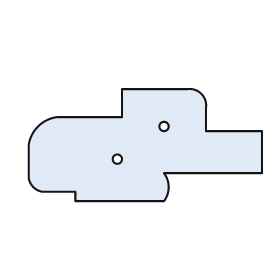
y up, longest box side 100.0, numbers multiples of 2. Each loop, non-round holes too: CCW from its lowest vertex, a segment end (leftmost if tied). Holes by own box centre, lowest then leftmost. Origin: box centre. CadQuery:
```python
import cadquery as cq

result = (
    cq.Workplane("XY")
    .moveTo(-30.0, -24.0)
    .lineTo(8.0, -24.0)
    .threePointArc((10.0, -18.0), (8.0, -12.0))
    .lineTo(50.0, -12.0)
    .lineTo(50.0, 6.0)
    .lineTo(26.0, 6.0)
    .lineTo(26.0, 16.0)
    .threePointArc((24.0, 22.0), (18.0, 24.0))
    .lineTo(-10.0, 24.0)
    .lineTo(-10.0, 12.0)
    .lineTo(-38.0, 12.0)
    .threePointArc((-46.0, 8.0), (-50.0, 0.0))
    .lineTo(-50.0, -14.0)
    .threePointArc((-48.0, -18.0), (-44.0, -20.0))
    .lineTo(-30.0, -20.0)
    .close()
    .moveTo(-12.0, -6.0)
    .circle(2.0)
    .moveTo(8.0, 8.0)
    .circle(2.0)
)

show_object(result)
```